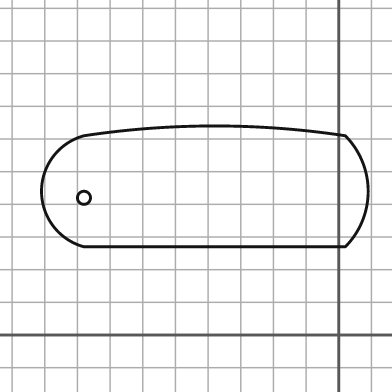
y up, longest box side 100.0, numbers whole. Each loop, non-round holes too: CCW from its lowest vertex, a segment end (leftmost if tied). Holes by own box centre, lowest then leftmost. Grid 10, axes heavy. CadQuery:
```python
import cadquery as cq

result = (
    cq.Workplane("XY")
    .moveTo(-78.0, 27.0)
    .lineTo(2.0, 27.0)
    .threePointArc((9.0, 44.0), (2.0, 61.0))
    .threePointArc((-38.0, 64.0), (-78.0, 61.0))
    .threePointArc((-91.0, 44.0), (-78.0, 27.0))
    .close()
    .moveTo(-78.0, 42.0)
    .circle(2.0)
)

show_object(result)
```